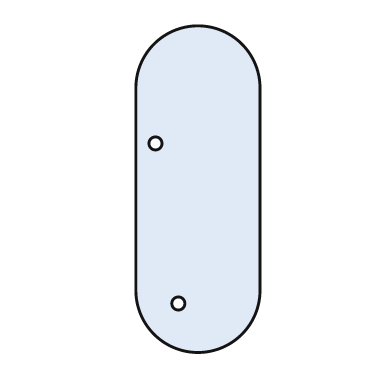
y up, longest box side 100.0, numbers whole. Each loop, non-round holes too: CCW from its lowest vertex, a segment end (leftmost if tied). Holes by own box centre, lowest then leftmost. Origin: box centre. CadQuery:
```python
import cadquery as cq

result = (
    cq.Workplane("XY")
    .moveTo(-19.0, -31.0)
    .threePointArc((0.0, -50.0), (19.0, -31.0))
    .lineTo(19.0, 31.0)
    .threePointArc((0.0, 50.0), (-19.0, 31.0))
    .close()
    .moveTo(-6.0, -35.0)
    .circle(2.0)
    .moveTo(-13.0, 14.0)
    .circle(2.0)
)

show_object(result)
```